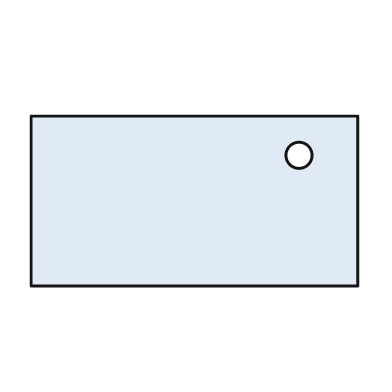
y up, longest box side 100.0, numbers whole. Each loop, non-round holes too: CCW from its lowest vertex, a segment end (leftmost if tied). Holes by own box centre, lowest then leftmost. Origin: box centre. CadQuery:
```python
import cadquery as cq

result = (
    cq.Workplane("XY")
    .moveTo(-50.0, -26.0)
    .lineTo(50.0, -26.0)
    .lineTo(50.0, 26.0)
    .lineTo(-50.0, 26.0)
    .close()
    .moveTo(32.0, 14.0)
    .circle(4.0)
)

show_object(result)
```